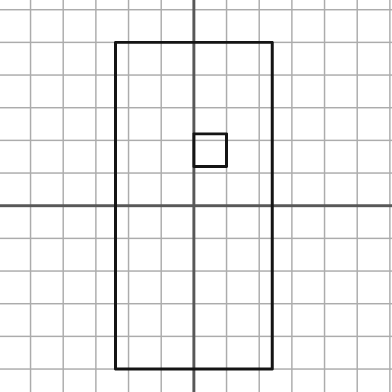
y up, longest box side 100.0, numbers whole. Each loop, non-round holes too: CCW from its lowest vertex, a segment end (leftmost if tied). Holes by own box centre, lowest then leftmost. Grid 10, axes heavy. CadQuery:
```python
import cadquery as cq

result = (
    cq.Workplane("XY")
    .moveTo(-24.0, -50.0)
    .lineTo(24.0, -50.0)
    .lineTo(24.0, 50.0)
    .lineTo(-24.0, 50.0)
    .close()
    .moveTo(0.0, 12.0)
    .lineTo(10.0, 12.0)
    .lineTo(10.0, 22.0)
    .lineTo(0.0, 22.0)
    .close()
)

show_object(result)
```